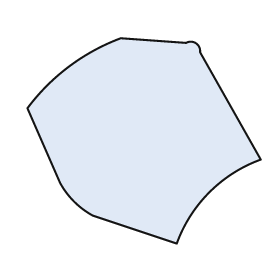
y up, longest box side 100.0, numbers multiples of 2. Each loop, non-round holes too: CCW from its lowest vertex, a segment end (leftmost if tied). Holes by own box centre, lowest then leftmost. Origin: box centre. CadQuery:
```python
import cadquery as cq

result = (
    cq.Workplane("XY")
    .moveTo(14.0, -44.0)
    .threePointArc((28.0, -22.0), (50.0, -8.0))
    .lineTo(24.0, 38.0)
    .threePointArc((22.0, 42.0), (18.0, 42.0))
    .lineTo(-10.0, 44.0)
    .threePointArc((-32.0, 32.0), (-50.0, 14.0))
    .lineTo(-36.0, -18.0)
    .threePointArc((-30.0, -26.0), (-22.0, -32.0))
    .close()
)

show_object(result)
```